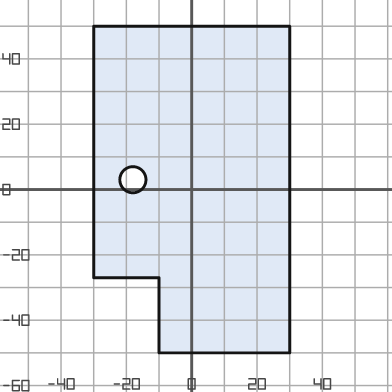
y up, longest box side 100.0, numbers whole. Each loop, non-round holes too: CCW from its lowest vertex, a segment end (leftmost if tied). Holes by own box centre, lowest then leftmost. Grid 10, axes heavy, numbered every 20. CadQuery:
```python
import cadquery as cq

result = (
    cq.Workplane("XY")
    .moveTo(-10.0, -50.0)
    .lineTo(30.0, -50.0)
    .lineTo(30.0, 50.0)
    .lineTo(-30.0, 50.0)
    .lineTo(-30.0, -27.0)
    .lineTo(-10.0, -27.0)
    .close()
    .moveTo(-18.0, 3.0)
    .circle(4.0)
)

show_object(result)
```